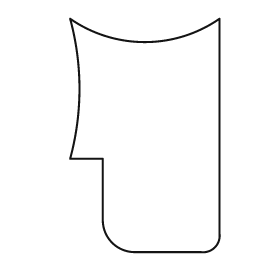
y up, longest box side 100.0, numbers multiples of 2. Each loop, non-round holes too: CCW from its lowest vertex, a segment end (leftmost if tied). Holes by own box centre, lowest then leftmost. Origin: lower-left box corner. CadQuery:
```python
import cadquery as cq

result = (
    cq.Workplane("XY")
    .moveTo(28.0, 0.0)
    .lineTo(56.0, 0.0)
    .threePointArc((62.0, 2.0), (64.0, 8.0))
    .lineTo(64.0, 100.0)
    .threePointArc((32.0, 90.0), (0.0, 100.0))
    .threePointArc((4.0, 70.0), (0.0, 40.0))
    .lineTo(14.0, 40.0)
    .lineTo(14.0, 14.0)
    .threePointArc((18.0, 4.0), (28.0, 0.0))
    .close()
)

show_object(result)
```